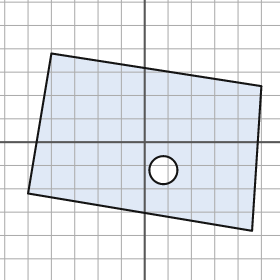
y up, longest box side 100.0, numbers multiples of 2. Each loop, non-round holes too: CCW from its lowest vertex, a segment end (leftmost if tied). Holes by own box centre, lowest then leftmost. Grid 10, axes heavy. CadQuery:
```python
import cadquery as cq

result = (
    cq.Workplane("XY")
    .moveTo(46.0, -38.0)
    .lineTo(50.0, 24.0)
    .lineTo(-40.0, 38.0)
    .lineTo(-50.0, -22.0)
    .close()
    .moveTo(8.0, -12.0)
    .circle(6.0)
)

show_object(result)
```